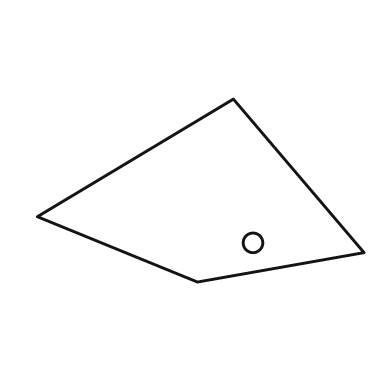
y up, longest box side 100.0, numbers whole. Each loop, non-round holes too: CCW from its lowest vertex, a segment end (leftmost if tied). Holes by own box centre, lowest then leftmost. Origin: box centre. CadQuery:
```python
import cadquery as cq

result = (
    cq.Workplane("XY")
    .moveTo(-1.0, -28.0)
    .lineTo(50.0, -19.0)
    .lineTo(10.0, 28.0)
    .lineTo(-50.0, -8.0)
    .close()
    .moveTo(16.0, -16.0)
    .circle(3.0)
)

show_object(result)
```